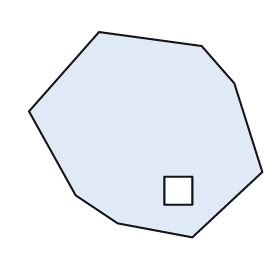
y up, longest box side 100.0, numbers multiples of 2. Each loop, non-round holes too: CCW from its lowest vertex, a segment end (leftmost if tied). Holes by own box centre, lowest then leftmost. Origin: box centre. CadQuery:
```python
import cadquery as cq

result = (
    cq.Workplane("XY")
    .moveTo(20.0, -44.0)
    .lineTo(50.0, -16.0)
    .lineTo(38.0, 22.0)
    .lineTo(24.0, 38.0)
    .lineTo(-20.0, 44.0)
    .lineTo(-50.0, 10.0)
    .lineTo(-30.0, -26.0)
    .lineTo(-12.0, -38.0)
    .close()
    .moveTo(8.0, -30.0)
    .lineTo(20.0, -30.0)
    .lineTo(20.0, -18.0)
    .lineTo(8.0, -18.0)
    .close()
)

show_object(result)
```